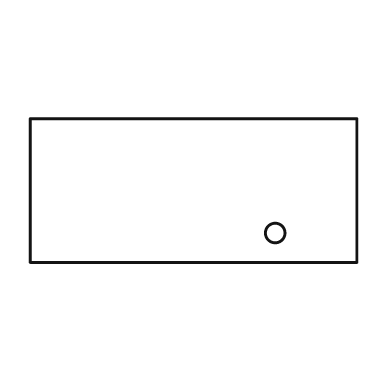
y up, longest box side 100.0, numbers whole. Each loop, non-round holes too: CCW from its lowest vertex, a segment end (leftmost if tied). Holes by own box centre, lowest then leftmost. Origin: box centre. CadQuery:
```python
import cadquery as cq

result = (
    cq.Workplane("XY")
    .moveTo(-50.0, -22.0)
    .lineTo(50.0, -22.0)
    .lineTo(50.0, 22.0)
    .lineTo(-50.0, 22.0)
    .close()
    .moveTo(25.0, -13.0)
    .circle(3.0)
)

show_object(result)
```